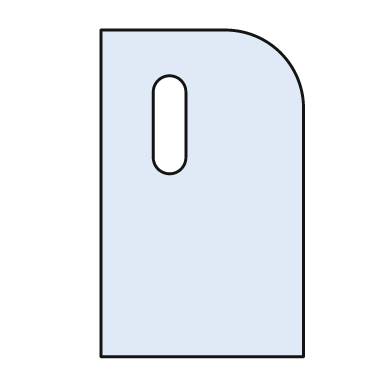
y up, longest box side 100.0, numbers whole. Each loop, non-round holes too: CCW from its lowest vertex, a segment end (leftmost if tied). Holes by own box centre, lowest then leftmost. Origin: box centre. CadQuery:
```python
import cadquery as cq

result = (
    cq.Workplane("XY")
    .moveTo(-31.0, -50.0)
    .lineTo(31.0, -50.0)
    .lineTo(31.0, 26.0)
    .threePointArc((24.0, 43.0), (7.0, 50.0))
    .lineTo(-31.0, 50.0)
    .close()
    .moveTo(-15.0, 11.0)
    .threePointArc((-10.0, 6.0), (-5.0, 11.0))
    .lineTo(-5.0, 31.0)
    .threePointArc((-10.0, 36.0), (-15.0, 31.0))
    .close()
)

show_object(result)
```